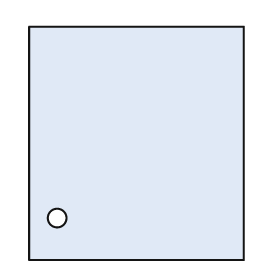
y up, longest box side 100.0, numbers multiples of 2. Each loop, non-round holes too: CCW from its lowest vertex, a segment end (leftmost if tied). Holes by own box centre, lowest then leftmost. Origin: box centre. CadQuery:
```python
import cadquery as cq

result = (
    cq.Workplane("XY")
    .moveTo(-46.0, -50.0)
    .lineTo(46.0, -50.0)
    .lineTo(46.0, 50.0)
    .lineTo(-46.0, 50.0)
    .close()
    .moveTo(-34.0, -32.0)
    .circle(4.0)
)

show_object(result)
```